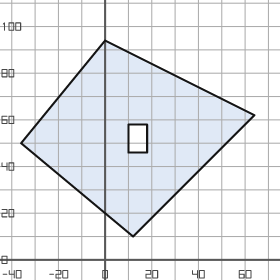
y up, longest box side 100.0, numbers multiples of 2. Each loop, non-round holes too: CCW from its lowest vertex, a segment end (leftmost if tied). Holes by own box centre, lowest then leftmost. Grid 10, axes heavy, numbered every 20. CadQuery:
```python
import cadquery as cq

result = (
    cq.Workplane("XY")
    .moveTo(12.0, 10.0)
    .lineTo(64.0, 62.0)
    .lineTo(0.0, 94.0)
    .lineTo(-36.0, 50.0)
    .close()
    .moveTo(10.0, 46.0)
    .lineTo(18.0, 46.0)
    .lineTo(18.0, 58.0)
    .lineTo(10.0, 58.0)
    .close()
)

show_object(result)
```